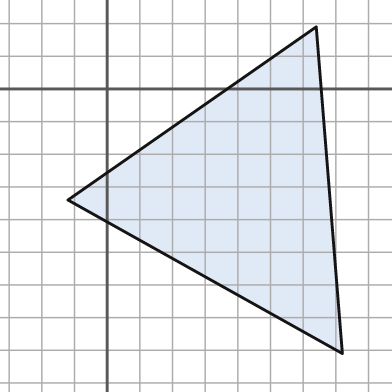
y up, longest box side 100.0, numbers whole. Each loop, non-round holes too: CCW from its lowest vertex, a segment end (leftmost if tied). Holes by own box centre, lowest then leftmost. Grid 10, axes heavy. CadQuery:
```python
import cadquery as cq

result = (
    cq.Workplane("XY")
    .moveTo(72.0, -81.0)
    .lineTo(64.0, 19.0)
    .lineTo(-12.0, -34.0)
    .close()
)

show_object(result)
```